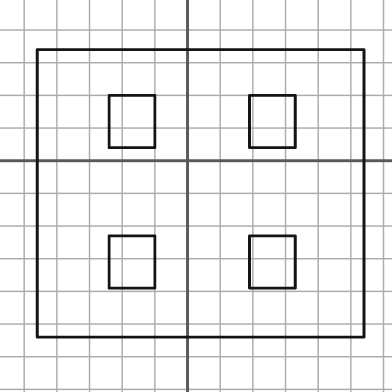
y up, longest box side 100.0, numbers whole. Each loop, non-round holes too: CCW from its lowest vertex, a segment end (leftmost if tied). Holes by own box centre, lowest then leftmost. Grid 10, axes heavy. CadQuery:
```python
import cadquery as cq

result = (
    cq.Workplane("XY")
    .moveTo(-46.0, -54.0)
    .lineTo(54.0, -54.0)
    .lineTo(54.0, 34.0)
    .lineTo(-46.0, 34.0)
    .close()
    .moveTo(-24.0, -39.0)
    .lineTo(-10.0, -39.0)
    .lineTo(-10.0, -23.0)
    .lineTo(-24.0, -23.0)
    .close()
    .moveTo(19.0, -39.0)
    .lineTo(33.0, -39.0)
    .lineTo(33.0, -23.0)
    .lineTo(19.0, -23.0)
    .close()
    .moveTo(-24.0, 4.0)
    .lineTo(-10.0, 4.0)
    .lineTo(-10.0, 20.0)
    .lineTo(-24.0, 20.0)
    .close()
    .moveTo(19.0, 4.0)
    .lineTo(33.0, 4.0)
    .lineTo(33.0, 20.0)
    .lineTo(19.0, 20.0)
    .close()
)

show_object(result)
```